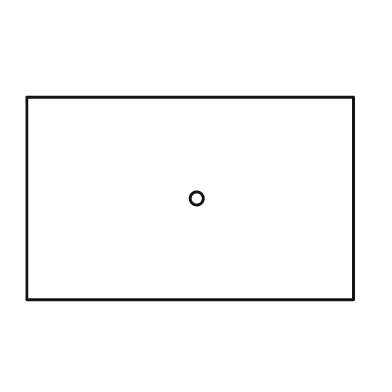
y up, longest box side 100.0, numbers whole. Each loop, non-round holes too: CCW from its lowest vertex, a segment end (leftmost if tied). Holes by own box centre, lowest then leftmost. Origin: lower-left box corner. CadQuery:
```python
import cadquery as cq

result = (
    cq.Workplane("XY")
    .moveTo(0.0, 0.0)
    .lineTo(100.0, 0.0)
    .lineTo(100.0, 62.0)
    .lineTo(0.0, 62.0)
    .close()
    .moveTo(52.0, 31.0)
    .circle(2.0)
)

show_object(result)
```